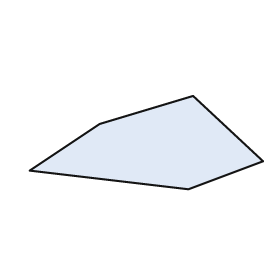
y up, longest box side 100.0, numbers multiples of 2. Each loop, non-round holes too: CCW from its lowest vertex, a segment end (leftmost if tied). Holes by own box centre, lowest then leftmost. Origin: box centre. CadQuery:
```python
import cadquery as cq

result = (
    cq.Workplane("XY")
    .moveTo(18.0, -20.0)
    .lineTo(50.0, -8.0)
    .lineTo(20.0, 20.0)
    .lineTo(-20.0, 8.0)
    .lineTo(-50.0, -12.0)
    .close()
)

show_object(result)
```